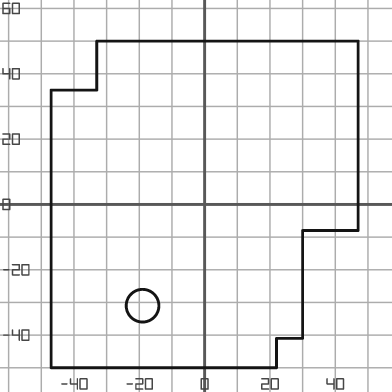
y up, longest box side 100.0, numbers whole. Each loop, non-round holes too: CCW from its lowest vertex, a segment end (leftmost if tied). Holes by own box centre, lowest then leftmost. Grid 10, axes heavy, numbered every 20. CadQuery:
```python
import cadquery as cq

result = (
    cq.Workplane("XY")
    .moveTo(-47.0, -50.0)
    .lineTo(22.0, -50.0)
    .lineTo(22.0, -41.0)
    .lineTo(30.0, -41.0)
    .lineTo(30.0, -8.0)
    .lineTo(47.0, -8.0)
    .lineTo(47.0, 50.0)
    .lineTo(-33.0, 50.0)
    .lineTo(-33.0, 35.0)
    .lineTo(-47.0, 35.0)
    .close()
    .moveTo(-19.0, -31.0)
    .circle(5.0)
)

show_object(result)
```